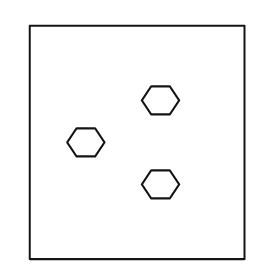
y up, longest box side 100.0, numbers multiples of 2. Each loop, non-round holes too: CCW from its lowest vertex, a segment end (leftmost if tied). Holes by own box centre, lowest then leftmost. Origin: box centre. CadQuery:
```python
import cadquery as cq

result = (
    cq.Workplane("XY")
    .moveTo(-46.0, -50.0)
    .lineTo(46.0, -50.0)
    .lineTo(46.0, 50.0)
    .lineTo(-46.0, 50.0)
    .close()
    .moveTo(6.0, -24.0)
    .lineTo(14.0, -24.0)
    .lineTo(18.0, -18.0)
    .lineTo(14.0, -12.0)
    .lineTo(6.0, -12.0)
    .lineTo(2.0, -18.0)
    .close()
    .moveTo(-26.0, -6.0)
    .lineTo(-18.0, -6.0)
    .lineTo(-14.0, 0.0)
    .lineTo(-18.0, 6.0)
    .lineTo(-26.0, 6.0)
    .lineTo(-30.0, 0.0)
    .close()
    .moveTo(6.0, 12.0)
    .lineTo(14.0, 12.0)
    .lineTo(18.0, 18.0)
    .lineTo(14.0, 24.0)
    .lineTo(6.0, 24.0)
    .lineTo(2.0, 18.0)
    .close()
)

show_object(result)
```